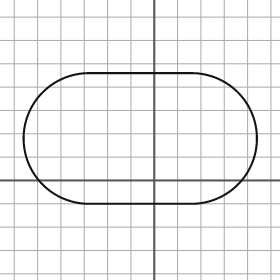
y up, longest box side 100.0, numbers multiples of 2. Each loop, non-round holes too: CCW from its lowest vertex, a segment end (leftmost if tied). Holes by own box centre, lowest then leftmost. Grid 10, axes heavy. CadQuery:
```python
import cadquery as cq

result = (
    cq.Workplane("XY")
    .moveTo(-28.0, -10.0)
    .lineTo(16.0, -10.0)
    .threePointArc((44.0, 18.0), (16.0, 46.0))
    .lineTo(-28.0, 46.0)
    .threePointArc((-56.0, 18.0), (-28.0, -10.0))
    .close()
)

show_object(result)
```